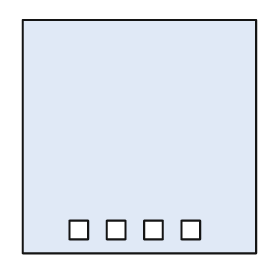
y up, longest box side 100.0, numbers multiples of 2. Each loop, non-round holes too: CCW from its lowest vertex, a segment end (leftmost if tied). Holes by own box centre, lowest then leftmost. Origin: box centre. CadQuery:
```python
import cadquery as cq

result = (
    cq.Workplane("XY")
    .moveTo(-50.0, -50.0)
    .lineTo(50.0, -50.0)
    .lineTo(50.0, 50.0)
    .lineTo(-50.0, 50.0)
    .close()
    .moveTo(-30.0, -44.0)
    .lineTo(-22.0, -44.0)
    .lineTo(-22.0, -36.0)
    .lineTo(-30.0, -36.0)
    .close()
    .moveTo(-14.0, -44.0)
    .lineTo(-6.0, -44.0)
    .lineTo(-6.0, -36.0)
    .lineTo(-14.0, -36.0)
    .close()
    .moveTo(2.0, -44.0)
    .lineTo(10.0, -44.0)
    .lineTo(10.0, -36.0)
    .lineTo(2.0, -36.0)
    .close()
    .moveTo(18.0, -44.0)
    .lineTo(26.0, -44.0)
    .lineTo(26.0, -36.0)
    .lineTo(18.0, -36.0)
    .close()
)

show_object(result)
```